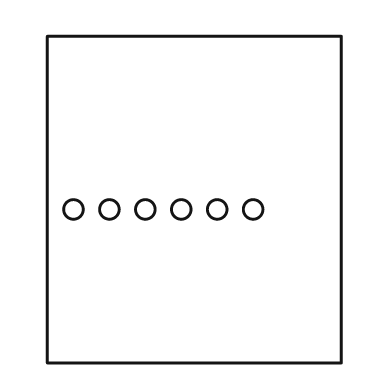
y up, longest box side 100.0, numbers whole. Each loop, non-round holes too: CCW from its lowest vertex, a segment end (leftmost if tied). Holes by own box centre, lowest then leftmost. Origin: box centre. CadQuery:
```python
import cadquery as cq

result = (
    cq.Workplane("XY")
    .moveTo(-45.0, -50.0)
    .lineTo(45.0, -50.0)
    .lineTo(45.0, 50.0)
    .lineTo(-45.0, 50.0)
    .close()
    .moveTo(-37.0, -3.0)
    .circle(3.0)
    .moveTo(-26.0, -3.0)
    .circle(3.0)
    .moveTo(-15.0, -3.0)
    .circle(3.0)
    .moveTo(-4.0, -3.0)
    .circle(3.0)
    .moveTo(7.0, -3.0)
    .circle(3.0)
    .moveTo(18.0, -3.0)
    .circle(3.0)
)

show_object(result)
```